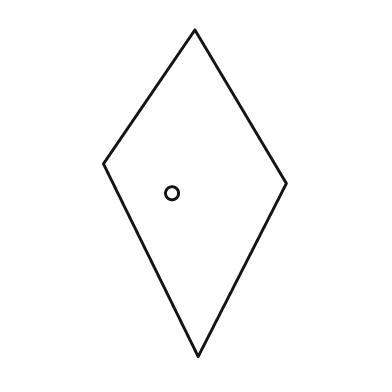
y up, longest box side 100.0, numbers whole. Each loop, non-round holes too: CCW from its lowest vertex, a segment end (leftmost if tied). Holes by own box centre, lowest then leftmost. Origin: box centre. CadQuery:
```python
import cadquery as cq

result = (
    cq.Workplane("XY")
    .moveTo(1.0, -50.0)
    .lineTo(28.0, 3.0)
    .lineTo(0.0, 50.0)
    .lineTo(-28.0, 9.0)
    .close()
    .moveTo(-7.0, 0.0)
    .circle(2.0)
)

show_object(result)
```